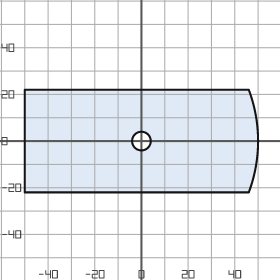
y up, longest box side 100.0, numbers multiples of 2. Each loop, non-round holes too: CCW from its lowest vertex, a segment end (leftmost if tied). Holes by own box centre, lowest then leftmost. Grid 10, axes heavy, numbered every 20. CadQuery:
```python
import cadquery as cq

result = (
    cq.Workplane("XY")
    .moveTo(-50.0, -22.0)
    .lineTo(46.0, -22.0)
    .threePointArc((50.0, 0.0), (46.0, 22.0))
    .lineTo(-50.0, 22.0)
    .close()
    .moveTo(0.0, 0.0)
    .circle(4.0)
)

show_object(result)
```